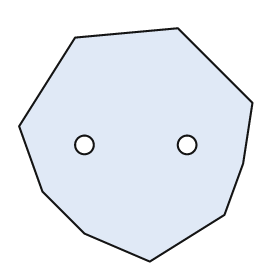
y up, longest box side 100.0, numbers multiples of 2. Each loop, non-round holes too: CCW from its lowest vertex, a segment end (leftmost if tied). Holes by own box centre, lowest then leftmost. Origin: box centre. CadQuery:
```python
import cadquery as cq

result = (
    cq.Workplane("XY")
    .moveTo(6.0, -50.0)
    .lineTo(38.0, -30.0)
    .lineTo(46.0, -8.0)
    .lineTo(50.0, 18.0)
    .lineTo(18.0, 50.0)
    .lineTo(-26.0, 46.0)
    .lineTo(-50.0, 8.0)
    .lineTo(-40.0, -20.0)
    .lineTo(-22.0, -38.0)
    .close()
    .moveTo(-22.0, 0.0)
    .circle(4.0)
    .moveTo(22.0, 0.0)
    .circle(4.0)
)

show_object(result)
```